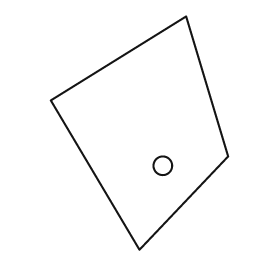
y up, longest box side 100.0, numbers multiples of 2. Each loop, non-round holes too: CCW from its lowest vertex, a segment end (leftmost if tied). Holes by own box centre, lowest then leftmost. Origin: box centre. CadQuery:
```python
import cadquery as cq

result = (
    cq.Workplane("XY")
    .moveTo(0.0, -50.0)
    .lineTo(38.0, -10.0)
    .lineTo(20.0, 50.0)
    .lineTo(-38.0, 14.0)
    .close()
    .moveTo(10.0, -14.0)
    .circle(4.0)
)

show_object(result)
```